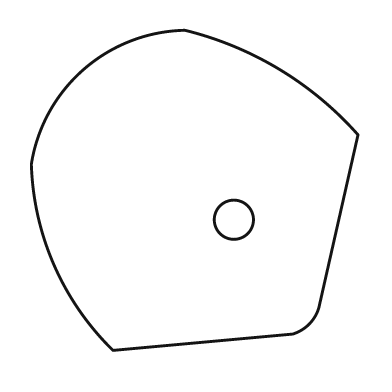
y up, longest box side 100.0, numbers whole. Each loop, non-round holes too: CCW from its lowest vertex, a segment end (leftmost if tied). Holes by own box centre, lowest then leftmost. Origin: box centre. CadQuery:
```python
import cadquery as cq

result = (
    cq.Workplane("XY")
    .moveTo(-25.0, -49.0)
    .lineTo(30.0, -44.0)
    .threePointArc((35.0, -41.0), (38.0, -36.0))
    .lineTo(50.0, 17.0)
    .threePointArc((26.0, 37.0), (-3.0, 49.0))
    .threePointArc((-34.0, 37.0), (-50.0, 8.0))
    .threePointArc((-43.0, -23.0), (-25.0, -49.0))
    .close()
    .moveTo(12.0, -9.0)
    .circle(6.0)
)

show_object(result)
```